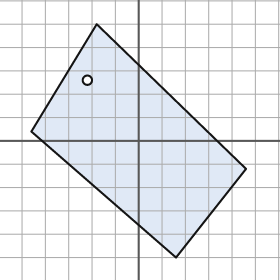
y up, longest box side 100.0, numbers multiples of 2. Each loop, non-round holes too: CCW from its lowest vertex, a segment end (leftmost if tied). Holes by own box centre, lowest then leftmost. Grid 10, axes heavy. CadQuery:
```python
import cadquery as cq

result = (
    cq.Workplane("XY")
    .moveTo(16.0, -50.0)
    .lineTo(46.0, -12.0)
    .lineTo(-18.0, 50.0)
    .lineTo(-46.0, 4.0)
    .close()
    .moveTo(-22.0, 26.0)
    .circle(2.0)
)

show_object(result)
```